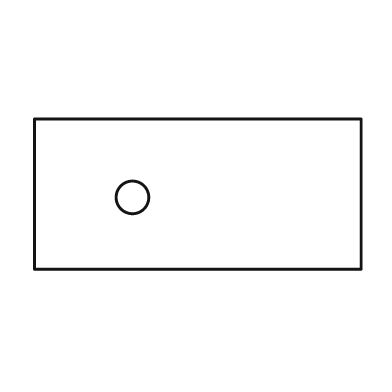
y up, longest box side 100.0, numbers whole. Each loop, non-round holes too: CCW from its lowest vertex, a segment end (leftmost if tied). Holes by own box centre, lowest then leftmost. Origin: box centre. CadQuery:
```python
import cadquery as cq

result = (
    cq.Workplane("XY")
    .moveTo(-50.0, -23.0)
    .lineTo(50.0, -23.0)
    .lineTo(50.0, 23.0)
    .lineTo(-50.0, 23.0)
    .close()
    .moveTo(-20.0, -1.0)
    .circle(5.0)
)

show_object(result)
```